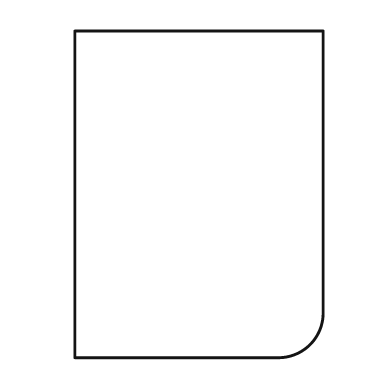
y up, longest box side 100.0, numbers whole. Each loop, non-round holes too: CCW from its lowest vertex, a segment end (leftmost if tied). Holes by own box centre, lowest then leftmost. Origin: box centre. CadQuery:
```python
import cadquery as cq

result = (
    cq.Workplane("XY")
    .moveTo(-38.0, -50.0)
    .lineTo(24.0, -50.0)
    .threePointArc((34.0, -46.0), (38.0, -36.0))
    .lineTo(38.0, 50.0)
    .lineTo(-38.0, 50.0)
    .close()
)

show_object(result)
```